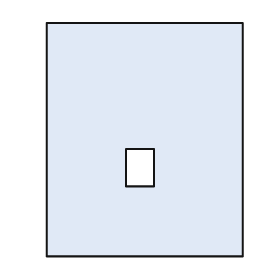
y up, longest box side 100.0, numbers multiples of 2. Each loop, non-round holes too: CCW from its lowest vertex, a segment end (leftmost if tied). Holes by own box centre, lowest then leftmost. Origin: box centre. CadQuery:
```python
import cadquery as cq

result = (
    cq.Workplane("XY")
    .moveTo(-42.0, -50.0)
    .lineTo(42.0, -50.0)
    .lineTo(42.0, 50.0)
    .lineTo(-42.0, 50.0)
    .close()
    .moveTo(-8.0, -20.0)
    .lineTo(4.0, -20.0)
    .lineTo(4.0, -4.0)
    .lineTo(-8.0, -4.0)
    .close()
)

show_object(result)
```